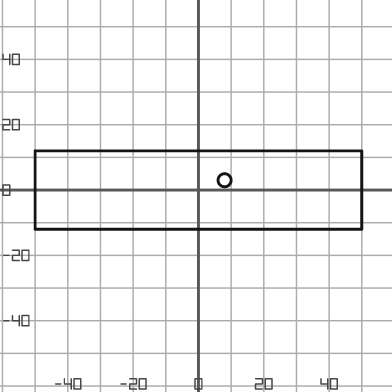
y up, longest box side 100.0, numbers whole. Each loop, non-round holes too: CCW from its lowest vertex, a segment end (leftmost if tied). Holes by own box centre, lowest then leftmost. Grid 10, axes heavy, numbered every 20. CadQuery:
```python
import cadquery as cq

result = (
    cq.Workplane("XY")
    .moveTo(-50.0, -12.0)
    .lineTo(50.0, -12.0)
    .lineTo(50.0, 12.0)
    .lineTo(-50.0, 12.0)
    .close()
    .moveTo(8.0, 3.0)
    .circle(2.0)
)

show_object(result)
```